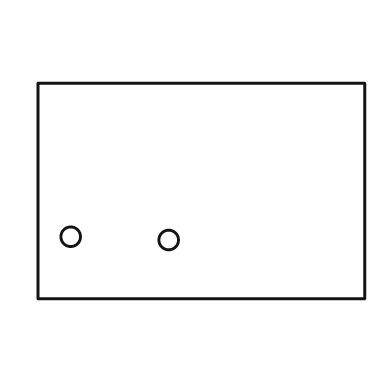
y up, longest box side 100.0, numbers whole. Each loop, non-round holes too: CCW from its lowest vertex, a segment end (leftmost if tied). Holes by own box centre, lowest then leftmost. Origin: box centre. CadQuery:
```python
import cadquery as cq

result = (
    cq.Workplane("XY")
    .moveTo(-50.0, -33.0)
    .lineTo(50.0, -33.0)
    .lineTo(50.0, 33.0)
    .lineTo(-50.0, 33.0)
    .close()
    .moveTo(-10.0, -15.0)
    .circle(3.0)
    .moveTo(-40.0, -14.0)
    .circle(3.0)
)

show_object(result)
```